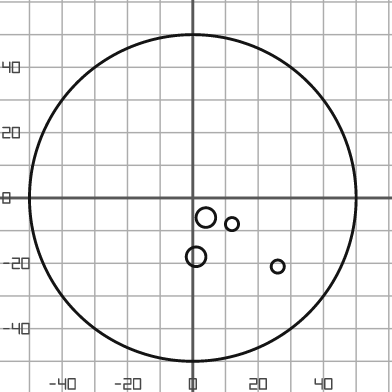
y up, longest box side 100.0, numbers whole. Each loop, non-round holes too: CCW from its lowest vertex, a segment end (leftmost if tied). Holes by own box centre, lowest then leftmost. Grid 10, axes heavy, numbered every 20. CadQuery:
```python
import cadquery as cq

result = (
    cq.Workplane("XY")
    .moveTo(0.0, 0.0)
    .circle(50.0)
    .moveTo(26.0, -21.0)
    .circle(2.0)
    .moveTo(1.0, -18.0)
    .circle(3.0)
    .moveTo(12.0, -8.0)
    .circle(2.0)
    .moveTo(4.0, -6.0)
    .circle(3.0)
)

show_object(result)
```